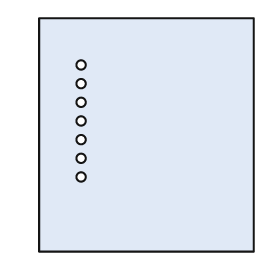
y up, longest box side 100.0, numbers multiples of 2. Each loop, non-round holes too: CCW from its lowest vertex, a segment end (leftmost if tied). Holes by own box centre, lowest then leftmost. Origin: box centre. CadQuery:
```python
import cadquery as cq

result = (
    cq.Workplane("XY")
    .moveTo(-46.0, -50.0)
    .lineTo(46.0, -50.0)
    .lineTo(46.0, 50.0)
    .lineTo(-46.0, 50.0)
    .close()
    .moveTo(-28.0, -18.0)
    .circle(2.0)
    .moveTo(-28.0, -10.0)
    .circle(2.0)
    .moveTo(-28.0, -2.0)
    .circle(2.0)
    .moveTo(-28.0, 6.0)
    .circle(2.0)
    .moveTo(-28.0, 14.0)
    .circle(2.0)
    .moveTo(-28.0, 22.0)
    .circle(2.0)
    .moveTo(-28.0, 30.0)
    .circle(2.0)
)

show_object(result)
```